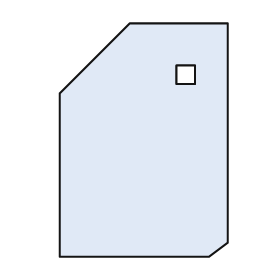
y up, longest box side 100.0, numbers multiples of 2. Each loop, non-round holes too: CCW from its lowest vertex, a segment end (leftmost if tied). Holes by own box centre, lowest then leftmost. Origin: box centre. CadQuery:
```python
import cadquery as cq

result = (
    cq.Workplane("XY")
    .moveTo(-36.0, -50.0)
    .lineTo(28.0, -50.0)
    .lineTo(36.0, -44.0)
    .lineTo(36.0, 50.0)
    .lineTo(-6.0, 50.0)
    .lineTo(-36.0, 20.0)
    .close()
    .moveTo(14.0, 24.0)
    .lineTo(22.0, 24.0)
    .lineTo(22.0, 32.0)
    .lineTo(14.0, 32.0)
    .close()
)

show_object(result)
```